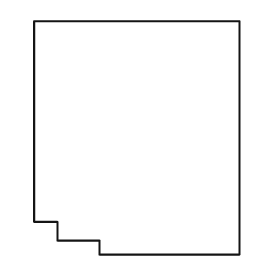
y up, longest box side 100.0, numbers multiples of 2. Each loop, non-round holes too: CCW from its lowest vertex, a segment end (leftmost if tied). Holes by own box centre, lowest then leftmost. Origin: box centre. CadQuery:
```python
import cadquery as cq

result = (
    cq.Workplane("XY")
    .moveTo(-16.0, -50.0)
    .lineTo(44.0, -50.0)
    .lineTo(44.0, 50.0)
    .lineTo(-44.0, 50.0)
    .lineTo(-44.0, -36.0)
    .lineTo(-34.0, -36.0)
    .lineTo(-34.0, -44.0)
    .lineTo(-16.0, -44.0)
    .close()
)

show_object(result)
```